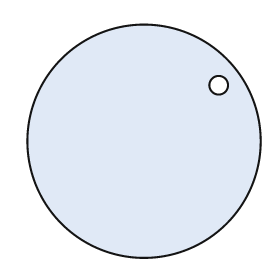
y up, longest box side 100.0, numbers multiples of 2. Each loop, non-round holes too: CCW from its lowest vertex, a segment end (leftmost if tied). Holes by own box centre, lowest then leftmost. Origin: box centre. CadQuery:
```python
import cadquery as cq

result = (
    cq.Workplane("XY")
    .moveTo(0.0, 0.0)
    .circle(50.0)
    .moveTo(32.0, 24.0)
    .circle(4.0)
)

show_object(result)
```